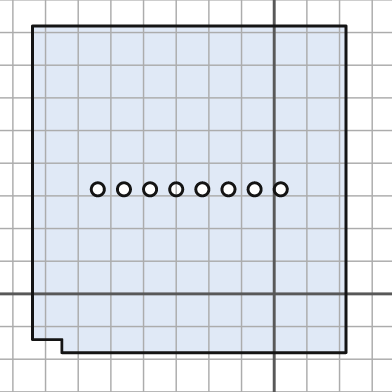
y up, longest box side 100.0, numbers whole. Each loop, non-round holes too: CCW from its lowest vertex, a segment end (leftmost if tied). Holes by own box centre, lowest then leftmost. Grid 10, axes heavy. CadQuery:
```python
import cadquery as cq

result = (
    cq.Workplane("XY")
    .moveTo(-65.0, -18.0)
    .lineTo(22.0, -18.0)
    .lineTo(22.0, 82.0)
    .lineTo(-74.0, 82.0)
    .lineTo(-74.0, -14.0)
    .lineTo(-65.0, -14.0)
    .close()
    .moveTo(-54.0, 32.0)
    .circle(2.0)
    .moveTo(-46.0, 32.0)
    .circle(2.0)
    .moveTo(-38.0, 32.0)
    .circle(2.0)
    .moveTo(-30.0, 32.0)
    .circle(2.0)
    .moveTo(-22.0, 32.0)
    .circle(2.0)
    .moveTo(-14.0, 32.0)
    .circle(2.0)
    .moveTo(-6.0, 32.0)
    .circle(2.0)
    .moveTo(2.0, 32.0)
    .circle(2.0)
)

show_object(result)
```